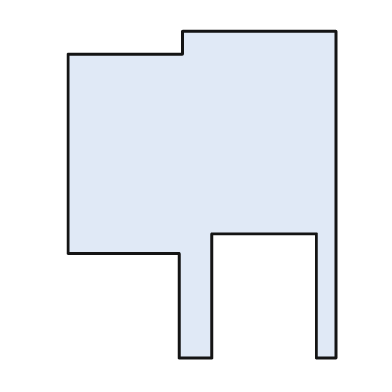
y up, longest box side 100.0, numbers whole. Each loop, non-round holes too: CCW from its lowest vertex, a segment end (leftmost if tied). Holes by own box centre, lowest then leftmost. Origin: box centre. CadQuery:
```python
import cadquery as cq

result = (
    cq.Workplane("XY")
    .moveTo(-7.0, -50.0)
    .lineTo(3.0, -50.0)
    .lineTo(3.0, -12.0)
    .lineTo(35.0, -12.0)
    .lineTo(35.0, -50.0)
    .lineTo(41.0, -50.0)
    .lineTo(41.0, 50.0)
    .lineTo(-6.0, 50.0)
    .lineTo(-6.0, 43.0)
    .lineTo(-41.0, 43.0)
    .lineTo(-41.0, -18.0)
    .lineTo(-7.0, -18.0)
    .close()
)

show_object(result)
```